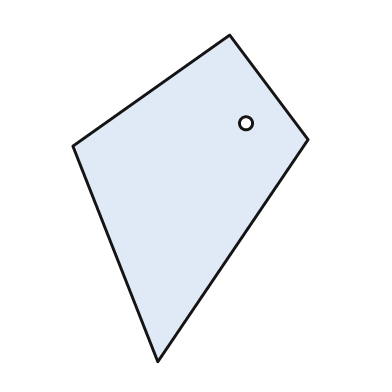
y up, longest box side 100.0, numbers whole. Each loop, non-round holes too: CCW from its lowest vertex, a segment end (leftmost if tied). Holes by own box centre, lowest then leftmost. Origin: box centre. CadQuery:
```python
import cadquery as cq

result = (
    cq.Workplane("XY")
    .moveTo(-10.0, -50.0)
    .lineTo(36.0, 18.0)
    .lineTo(12.0, 50.0)
    .lineTo(-36.0, 16.0)
    .close()
    .moveTo(17.0, 23.0)
    .circle(2.0)
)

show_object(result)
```